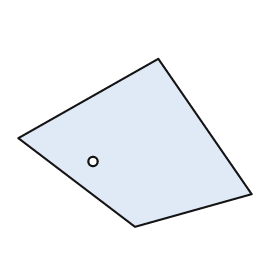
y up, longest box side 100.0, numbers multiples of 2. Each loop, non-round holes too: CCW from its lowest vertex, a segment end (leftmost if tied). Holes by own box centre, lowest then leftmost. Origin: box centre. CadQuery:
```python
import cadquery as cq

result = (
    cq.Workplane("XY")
    .moveTo(0.0, -36.0)
    .lineTo(50.0, -22.0)
    .lineTo(10.0, 36.0)
    .lineTo(-50.0, 2.0)
    .close()
    .moveTo(-18.0, -8.0)
    .circle(2.0)
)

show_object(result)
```